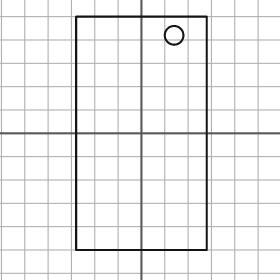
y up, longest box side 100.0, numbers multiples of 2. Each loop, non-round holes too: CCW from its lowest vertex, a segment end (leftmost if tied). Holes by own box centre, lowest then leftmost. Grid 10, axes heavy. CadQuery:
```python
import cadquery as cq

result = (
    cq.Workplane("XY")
    .moveTo(-28.0, -50.0)
    .lineTo(28.0, -50.0)
    .lineTo(28.0, 50.0)
    .lineTo(-28.0, 50.0)
    .close()
    .moveTo(14.0, 42.0)
    .circle(4.0)
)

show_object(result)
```